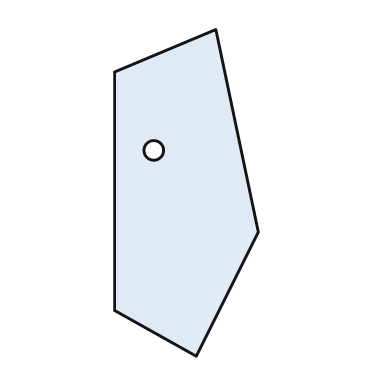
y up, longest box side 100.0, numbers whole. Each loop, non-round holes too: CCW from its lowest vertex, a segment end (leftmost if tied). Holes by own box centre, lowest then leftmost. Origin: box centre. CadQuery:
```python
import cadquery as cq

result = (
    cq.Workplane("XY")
    .moveTo(3.0, -50.0)
    .lineTo(22.0, -12.0)
    .lineTo(9.0, 50.0)
    .lineTo(-22.0, 37.0)
    .lineTo(-22.0, -36.0)
    .close()
    .moveTo(-10.0, 13.0)
    .circle(3.0)
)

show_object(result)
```